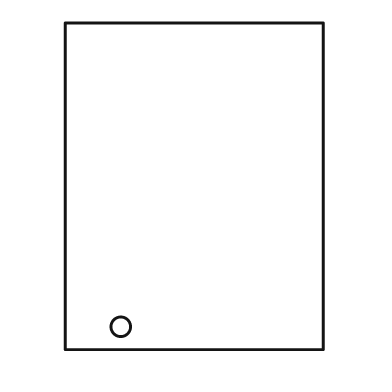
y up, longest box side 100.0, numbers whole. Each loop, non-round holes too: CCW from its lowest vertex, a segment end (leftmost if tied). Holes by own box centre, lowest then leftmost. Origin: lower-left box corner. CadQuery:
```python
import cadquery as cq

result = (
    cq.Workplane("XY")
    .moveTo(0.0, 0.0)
    .lineTo(79.0, 0.0)
    .lineTo(79.0, 100.0)
    .lineTo(0.0, 100.0)
    .close()
    .moveTo(17.0, 7.0)
    .circle(3.0)
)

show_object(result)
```